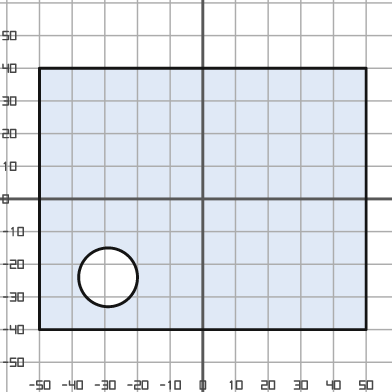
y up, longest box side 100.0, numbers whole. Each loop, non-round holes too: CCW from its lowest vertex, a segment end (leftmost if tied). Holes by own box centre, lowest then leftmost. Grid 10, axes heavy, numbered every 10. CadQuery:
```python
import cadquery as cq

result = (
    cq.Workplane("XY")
    .moveTo(-50.0, -40.0)
    .lineTo(50.0, -40.0)
    .lineTo(50.0, 40.0)
    .lineTo(-50.0, 40.0)
    .close()
    .moveTo(-29.0, -24.0)
    .circle(9.0)
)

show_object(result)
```